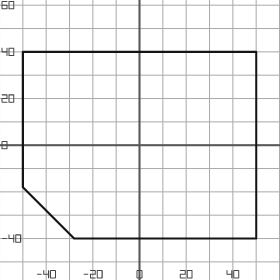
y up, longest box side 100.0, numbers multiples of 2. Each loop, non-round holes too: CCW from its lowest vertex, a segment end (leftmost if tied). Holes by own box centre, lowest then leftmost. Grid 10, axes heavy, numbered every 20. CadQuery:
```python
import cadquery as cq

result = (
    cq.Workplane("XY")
    .moveTo(-28.0, -40.0)
    .lineTo(50.0, -40.0)
    .lineTo(50.0, 40.0)
    .lineTo(-50.0, 40.0)
    .lineTo(-50.0, -18.0)
    .close()
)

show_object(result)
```